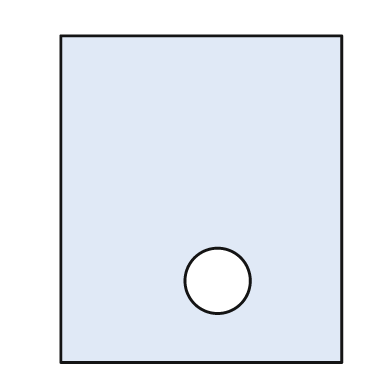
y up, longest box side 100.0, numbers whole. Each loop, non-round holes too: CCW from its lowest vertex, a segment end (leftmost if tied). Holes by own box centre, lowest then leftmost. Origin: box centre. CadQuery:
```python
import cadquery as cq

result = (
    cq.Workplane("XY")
    .moveTo(-43.0, -50.0)
    .lineTo(43.0, -50.0)
    .lineTo(43.0, 50.0)
    .lineTo(-43.0, 50.0)
    .close()
    .moveTo(5.0, -25.0)
    .circle(10.0)
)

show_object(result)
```